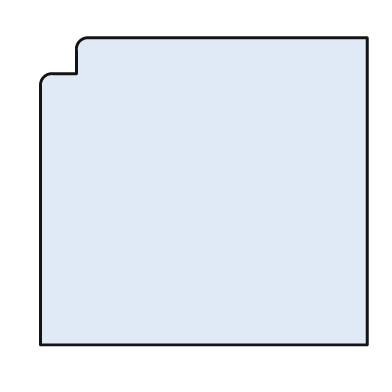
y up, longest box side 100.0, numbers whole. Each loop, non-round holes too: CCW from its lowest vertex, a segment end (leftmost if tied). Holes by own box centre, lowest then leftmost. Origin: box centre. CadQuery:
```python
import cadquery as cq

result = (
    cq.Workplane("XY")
    .moveTo(-50.0, -47.0)
    .lineTo(50.0, -47.0)
    .lineTo(50.0, 47.0)
    .lineTo(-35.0, 47.0)
    .threePointArc((-38.0, 46.0), (-39.0, 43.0))
    .lineTo(-39.0, 36.0)
    .lineTo(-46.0, 36.0)
    .threePointArc((-49.0, 35.0), (-50.0, 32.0))
    .close()
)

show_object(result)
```